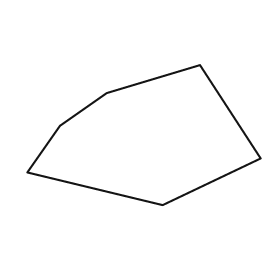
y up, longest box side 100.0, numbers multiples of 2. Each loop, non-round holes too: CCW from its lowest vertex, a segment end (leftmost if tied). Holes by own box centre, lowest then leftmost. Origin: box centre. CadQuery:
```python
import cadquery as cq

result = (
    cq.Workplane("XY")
    .moveTo(8.0, -30.0)
    .lineTo(50.0, -10.0)
    .lineTo(24.0, 30.0)
    .lineTo(-16.0, 18.0)
    .lineTo(-36.0, 4.0)
    .lineTo(-50.0, -16.0)
    .close()
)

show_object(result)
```